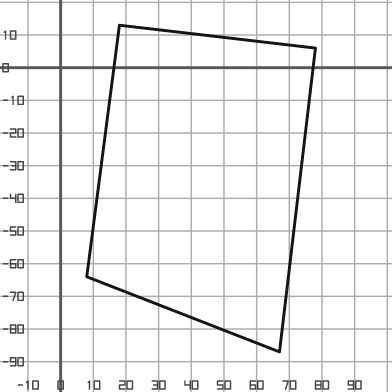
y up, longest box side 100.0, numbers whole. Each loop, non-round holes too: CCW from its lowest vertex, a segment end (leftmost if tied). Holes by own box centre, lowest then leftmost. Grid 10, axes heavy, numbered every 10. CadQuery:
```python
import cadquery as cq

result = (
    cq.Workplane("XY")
    .moveTo(67.0, -87.0)
    .lineTo(78.0, 6.0)
    .lineTo(18.0, 13.0)
    .lineTo(8.0, -64.0)
    .close()
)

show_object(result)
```